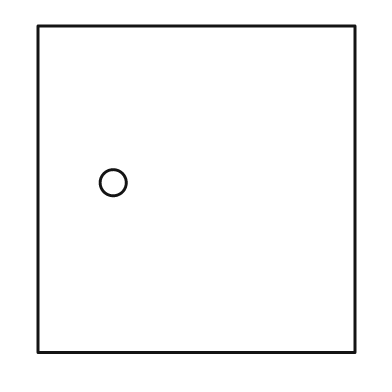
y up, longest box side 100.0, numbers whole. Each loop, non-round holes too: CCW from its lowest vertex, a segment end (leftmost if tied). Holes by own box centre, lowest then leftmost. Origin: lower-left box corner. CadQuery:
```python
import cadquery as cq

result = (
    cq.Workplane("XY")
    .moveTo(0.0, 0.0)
    .lineTo(97.0, 0.0)
    .lineTo(97.0, 100.0)
    .lineTo(0.0, 100.0)
    .close()
    .moveTo(23.0, 52.0)
    .circle(4.0)
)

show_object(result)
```